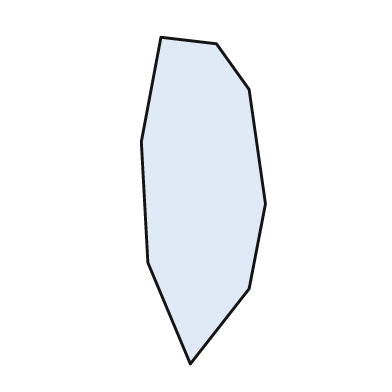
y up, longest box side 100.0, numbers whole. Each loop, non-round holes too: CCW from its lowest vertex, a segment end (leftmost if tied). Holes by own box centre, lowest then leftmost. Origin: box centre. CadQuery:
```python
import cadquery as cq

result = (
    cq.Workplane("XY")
    .moveTo(-4.0, -50.0)
    .lineTo(14.0, -27.0)
    .lineTo(19.0, -1.0)
    .lineTo(14.0, 34.0)
    .lineTo(4.0, 48.0)
    .lineTo(-13.0, 50.0)
    .lineTo(-19.0, 18.0)
    .lineTo(-17.0, -19.0)
    .close()
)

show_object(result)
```